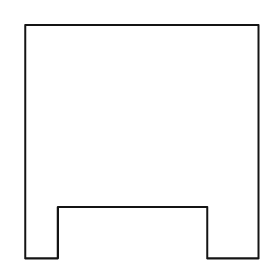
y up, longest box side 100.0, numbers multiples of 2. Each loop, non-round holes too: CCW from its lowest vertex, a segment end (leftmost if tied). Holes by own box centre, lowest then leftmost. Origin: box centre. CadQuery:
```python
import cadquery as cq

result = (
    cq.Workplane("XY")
    .moveTo(-50.0, -50.0)
    .lineTo(-36.0, -50.0)
    .lineTo(-36.0, -28.0)
    .lineTo(28.0, -28.0)
    .lineTo(28.0, -50.0)
    .lineTo(50.0, -50.0)
    .lineTo(50.0, 50.0)
    .lineTo(-50.0, 50.0)
    .close()
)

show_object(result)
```